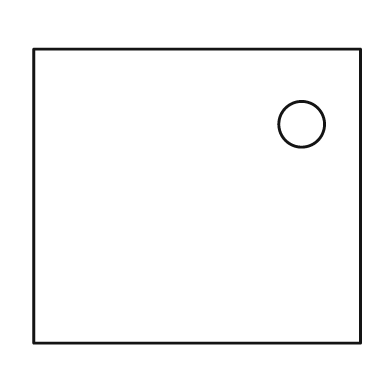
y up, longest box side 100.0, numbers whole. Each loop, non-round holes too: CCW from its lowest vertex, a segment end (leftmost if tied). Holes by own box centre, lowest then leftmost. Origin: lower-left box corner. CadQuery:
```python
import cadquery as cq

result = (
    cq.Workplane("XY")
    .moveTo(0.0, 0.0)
    .lineTo(100.0, 0.0)
    .lineTo(100.0, 90.0)
    .lineTo(0.0, 90.0)
    .close()
    .moveTo(82.0, 67.0)
    .circle(7.0)
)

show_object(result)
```